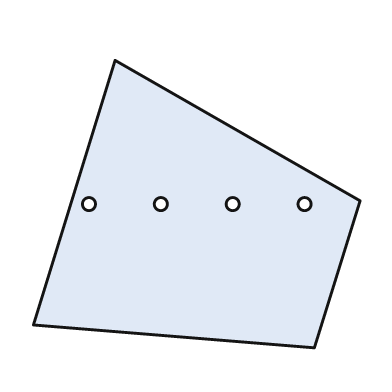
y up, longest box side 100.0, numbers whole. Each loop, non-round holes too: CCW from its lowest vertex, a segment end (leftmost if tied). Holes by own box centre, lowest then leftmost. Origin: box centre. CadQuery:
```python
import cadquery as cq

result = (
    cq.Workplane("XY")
    .moveTo(36.0, -44.0)
    .lineTo(50.0, 1.0)
    .lineTo(-25.0, 44.0)
    .lineTo(-50.0, -37.0)
    .close()
    .moveTo(-33.0, 0.0)
    .circle(2.0)
    .moveTo(-11.0, 0.0)
    .circle(2.0)
    .moveTo(11.0, 0.0)
    .circle(2.0)
    .moveTo(33.0, 0.0)
    .circle(2.0)
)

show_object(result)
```